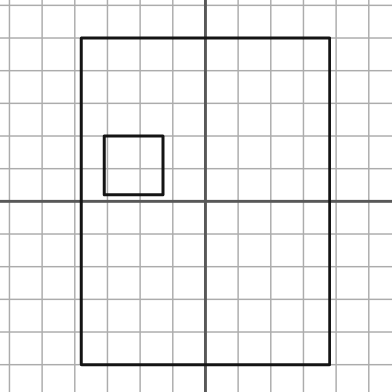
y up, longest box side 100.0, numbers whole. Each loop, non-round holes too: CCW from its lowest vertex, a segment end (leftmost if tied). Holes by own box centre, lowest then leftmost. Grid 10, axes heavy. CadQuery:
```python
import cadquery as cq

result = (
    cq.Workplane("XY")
    .moveTo(-38.0, -50.0)
    .lineTo(38.0, -50.0)
    .lineTo(38.0, 50.0)
    .lineTo(-38.0, 50.0)
    .close()
    .moveTo(-31.0, 2.0)
    .lineTo(-13.0, 2.0)
    .lineTo(-13.0, 20.0)
    .lineTo(-31.0, 20.0)
    .close()
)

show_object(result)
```